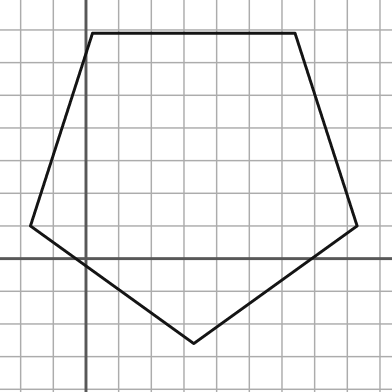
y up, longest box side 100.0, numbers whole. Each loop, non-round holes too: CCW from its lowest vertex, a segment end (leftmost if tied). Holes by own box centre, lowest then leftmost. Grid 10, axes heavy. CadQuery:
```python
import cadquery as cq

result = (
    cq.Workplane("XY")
    .moveTo(33.0, -26.0)
    .lineTo(83.0, 10.0)
    .lineTo(64.0, 69.0)
    .lineTo(2.0, 69.0)
    .lineTo(-17.0, 10.0)
    .close()
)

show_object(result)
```